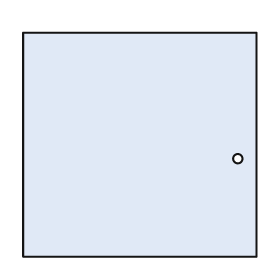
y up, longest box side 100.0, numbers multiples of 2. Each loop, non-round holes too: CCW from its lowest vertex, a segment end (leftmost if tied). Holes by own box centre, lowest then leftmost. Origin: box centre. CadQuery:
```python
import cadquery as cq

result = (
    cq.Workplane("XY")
    .moveTo(-50.0, -48.0)
    .lineTo(50.0, -48.0)
    .lineTo(50.0, 48.0)
    .lineTo(-50.0, 48.0)
    .close()
    .moveTo(42.0, -6.0)
    .circle(2.0)
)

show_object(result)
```